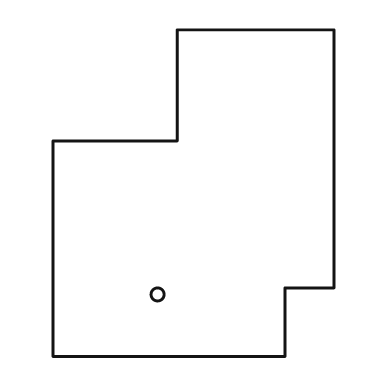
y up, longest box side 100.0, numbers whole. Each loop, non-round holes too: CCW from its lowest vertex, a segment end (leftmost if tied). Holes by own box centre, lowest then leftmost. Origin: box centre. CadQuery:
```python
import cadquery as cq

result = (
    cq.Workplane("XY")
    .moveTo(-43.0, -50.0)
    .lineTo(28.0, -50.0)
    .lineTo(28.0, -29.0)
    .lineTo(43.0, -29.0)
    .lineTo(43.0, 50.0)
    .lineTo(-5.0, 50.0)
    .lineTo(-5.0, 16.0)
    .lineTo(-43.0, 16.0)
    .close()
    .moveTo(-11.0, -31.0)
    .circle(2.0)
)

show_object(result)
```